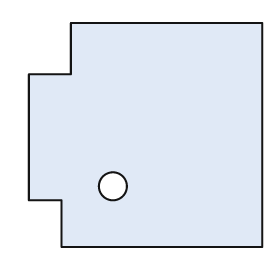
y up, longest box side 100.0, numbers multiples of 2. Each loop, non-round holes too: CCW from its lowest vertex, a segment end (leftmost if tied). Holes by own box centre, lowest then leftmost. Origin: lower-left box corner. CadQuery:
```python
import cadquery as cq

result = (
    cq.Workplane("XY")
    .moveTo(14.0, 0.0)
    .lineTo(100.0, 0.0)
    .lineTo(100.0, 96.0)
    .lineTo(18.0, 96.0)
    .lineTo(18.0, 74.0)
    .lineTo(0.0, 74.0)
    .lineTo(0.0, 20.0)
    .lineTo(14.0, 20.0)
    .close()
    .moveTo(36.0, 26.0)
    .circle(6.0)
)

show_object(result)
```